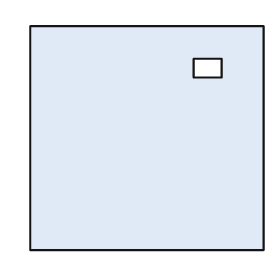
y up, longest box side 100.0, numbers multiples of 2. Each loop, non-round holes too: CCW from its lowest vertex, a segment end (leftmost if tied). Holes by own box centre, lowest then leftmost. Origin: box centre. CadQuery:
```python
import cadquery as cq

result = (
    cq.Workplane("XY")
    .moveTo(-50.0, -48.0)
    .lineTo(50.0, -48.0)
    .lineTo(50.0, 48.0)
    .lineTo(-50.0, 48.0)
    .close()
    .moveTo(20.0, 26.0)
    .lineTo(32.0, 26.0)
    .lineTo(32.0, 34.0)
    .lineTo(20.0, 34.0)
    .close()
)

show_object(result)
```